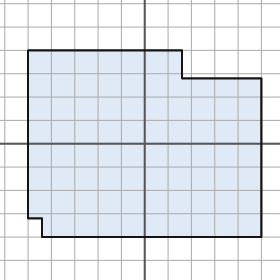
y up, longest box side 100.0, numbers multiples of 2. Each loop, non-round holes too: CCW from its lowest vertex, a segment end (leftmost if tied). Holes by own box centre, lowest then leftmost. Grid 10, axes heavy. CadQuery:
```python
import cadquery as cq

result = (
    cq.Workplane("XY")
    .moveTo(-44.0, -40.0)
    .lineTo(50.0, -40.0)
    .lineTo(50.0, 28.0)
    .lineTo(16.0, 28.0)
    .lineTo(16.0, 40.0)
    .lineTo(-50.0, 40.0)
    .lineTo(-50.0, -32.0)
    .lineTo(-44.0, -32.0)
    .close()
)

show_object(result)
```